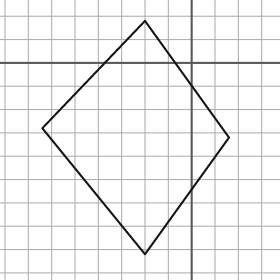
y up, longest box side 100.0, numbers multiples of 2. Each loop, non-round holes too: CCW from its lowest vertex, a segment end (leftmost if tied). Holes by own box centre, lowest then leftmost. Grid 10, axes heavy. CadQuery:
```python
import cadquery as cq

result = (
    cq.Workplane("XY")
    .moveTo(-20.0, -82.0)
    .lineTo(16.0, -32.0)
    .lineTo(-20.0, 18.0)
    .lineTo(-64.0, -28.0)
    .close()
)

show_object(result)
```